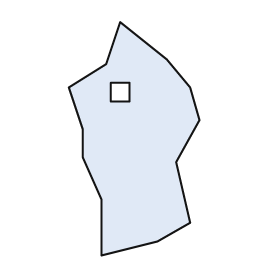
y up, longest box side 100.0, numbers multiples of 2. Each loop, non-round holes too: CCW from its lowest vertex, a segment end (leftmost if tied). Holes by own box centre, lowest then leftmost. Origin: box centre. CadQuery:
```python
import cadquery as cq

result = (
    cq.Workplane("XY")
    .moveTo(-14.0, -50.0)
    .lineTo(10.0, -44.0)
    .lineTo(24.0, -36.0)
    .lineTo(18.0, -10.0)
    .lineTo(28.0, 8.0)
    .lineTo(24.0, 22.0)
    .lineTo(14.0, 34.0)
    .lineTo(-6.0, 50.0)
    .lineTo(-12.0, 32.0)
    .lineTo(-28.0, 22.0)
    .lineTo(-22.0, 4.0)
    .lineTo(-22.0, -8.0)
    .lineTo(-14.0, -26.0)
    .close()
    .moveTo(-10.0, 16.0)
    .lineTo(-2.0, 16.0)
    .lineTo(-2.0, 24.0)
    .lineTo(-10.0, 24.0)
    .close()
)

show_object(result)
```